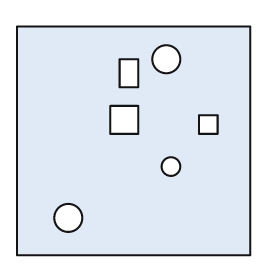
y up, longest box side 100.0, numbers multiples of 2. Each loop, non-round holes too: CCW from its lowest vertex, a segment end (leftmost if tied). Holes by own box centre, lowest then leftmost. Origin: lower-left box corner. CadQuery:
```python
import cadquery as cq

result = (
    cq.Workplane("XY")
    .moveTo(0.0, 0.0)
    .lineTo(100.0, 0.0)
    .lineTo(100.0, 98.0)
    .lineTo(0.0, 98.0)
    .close()
    .moveTo(22.0, 16.0)
    .circle(6.0)
    .moveTo(66.0, 38.0)
    .circle(4.0)
    .moveTo(78.0, 52.0)
    .lineTo(86.0, 52.0)
    .lineTo(86.0, 60.0)
    .lineTo(78.0, 60.0)
    .close()
    .moveTo(40.0, 52.0)
    .lineTo(52.0, 52.0)
    .lineTo(52.0, 64.0)
    .lineTo(40.0, 64.0)
    .close()
    .moveTo(44.0, 72.0)
    .lineTo(52.0, 72.0)
    .lineTo(52.0, 84.0)
    .lineTo(44.0, 84.0)
    .close()
    .moveTo(64.0, 84.0)
    .circle(6.0)
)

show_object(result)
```